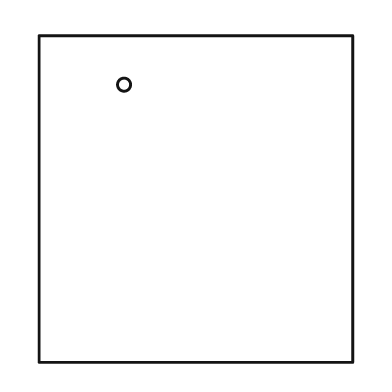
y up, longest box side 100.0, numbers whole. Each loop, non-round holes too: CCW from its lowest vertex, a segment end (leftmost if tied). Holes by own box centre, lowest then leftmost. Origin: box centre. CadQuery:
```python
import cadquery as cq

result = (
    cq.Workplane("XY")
    .moveTo(-48.0, -50.0)
    .lineTo(48.0, -50.0)
    .lineTo(48.0, 50.0)
    .lineTo(-48.0, 50.0)
    .close()
    .moveTo(-22.0, 35.0)
    .circle(2.0)
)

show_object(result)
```